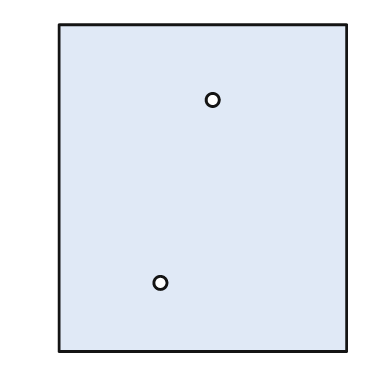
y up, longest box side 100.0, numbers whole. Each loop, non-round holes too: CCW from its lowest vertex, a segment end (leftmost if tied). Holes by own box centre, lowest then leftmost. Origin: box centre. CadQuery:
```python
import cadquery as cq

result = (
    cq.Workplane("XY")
    .moveTo(-44.0, -50.0)
    .lineTo(44.0, -50.0)
    .lineTo(44.0, 50.0)
    .lineTo(-44.0, 50.0)
    .close()
    .moveTo(-13.0, -29.0)
    .circle(2.0)
    .moveTo(3.0, 27.0)
    .circle(2.0)
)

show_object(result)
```